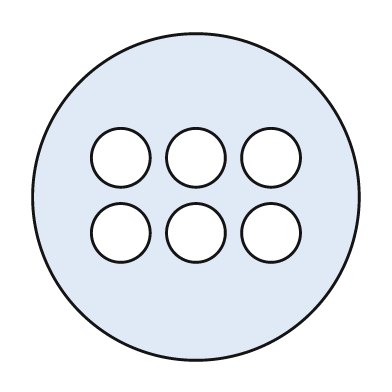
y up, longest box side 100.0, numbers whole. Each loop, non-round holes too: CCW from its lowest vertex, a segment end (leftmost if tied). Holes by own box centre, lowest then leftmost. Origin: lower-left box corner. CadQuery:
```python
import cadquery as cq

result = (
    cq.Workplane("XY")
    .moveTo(50.0, 50.0)
    .circle(50.0)
    .moveTo(27.0, 39.0)
    .circle(9.0)
    .moveTo(50.0, 39.0)
    .circle(9.0)
    .moveTo(73.0, 39.0)
    .circle(9.0)
    .moveTo(27.0, 62.0)
    .circle(9.0)
    .moveTo(50.0, 62.0)
    .circle(9.0)
    .moveTo(73.0, 62.0)
    .circle(9.0)
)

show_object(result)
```